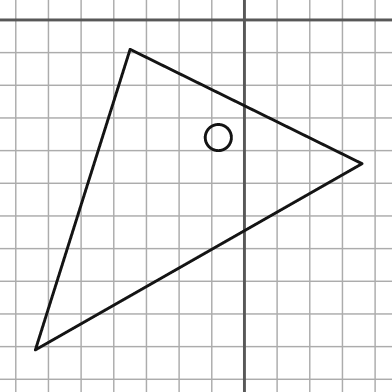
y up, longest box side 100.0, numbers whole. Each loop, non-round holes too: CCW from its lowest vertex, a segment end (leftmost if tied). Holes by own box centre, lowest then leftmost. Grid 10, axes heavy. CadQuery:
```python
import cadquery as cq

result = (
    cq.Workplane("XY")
    .moveTo(-64.0, -101.0)
    .lineTo(36.0, -44.0)
    .lineTo(-35.0, -9.0)
    .close()
    .moveTo(-8.0, -36.0)
    .circle(4.0)
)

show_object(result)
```